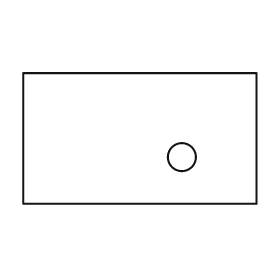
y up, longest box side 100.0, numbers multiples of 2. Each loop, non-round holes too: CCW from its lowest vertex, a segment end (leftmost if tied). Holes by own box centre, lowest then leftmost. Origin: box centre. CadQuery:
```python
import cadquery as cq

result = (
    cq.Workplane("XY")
    .moveTo(-50.0, -28.0)
    .lineTo(50.0, -28.0)
    .lineTo(50.0, 28.0)
    .lineTo(-50.0, 28.0)
    .close()
    .moveTo(18.0, -8.0)
    .circle(6.0)
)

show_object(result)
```